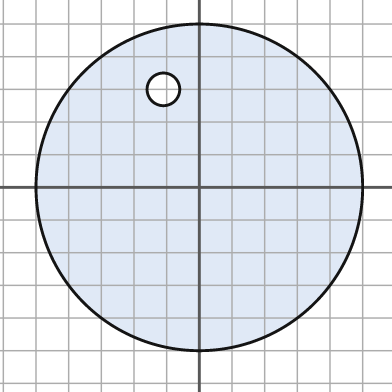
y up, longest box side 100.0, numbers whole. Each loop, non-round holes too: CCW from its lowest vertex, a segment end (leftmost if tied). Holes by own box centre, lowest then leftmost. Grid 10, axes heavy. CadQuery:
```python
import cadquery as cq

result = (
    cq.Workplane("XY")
    .moveTo(0.0, 0.0)
    .circle(50.0)
    .moveTo(-11.0, 30.0)
    .circle(5.0)
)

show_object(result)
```